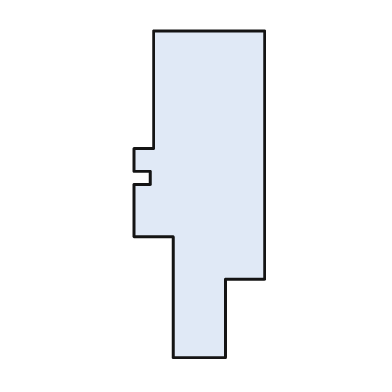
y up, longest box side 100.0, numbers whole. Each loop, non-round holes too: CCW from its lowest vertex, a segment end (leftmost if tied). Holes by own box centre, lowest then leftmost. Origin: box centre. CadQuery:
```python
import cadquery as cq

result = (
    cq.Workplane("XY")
    .moveTo(-8.0, -50.0)
    .lineTo(8.0, -50.0)
    .lineTo(8.0, -26.0)
    .lineTo(20.0, -26.0)
    .lineTo(20.0, 50.0)
    .lineTo(-14.0, 50.0)
    .lineTo(-14.0, 14.0)
    .lineTo(-20.0, 14.0)
    .lineTo(-20.0, 7.0)
    .lineTo(-15.0, 7.0)
    .lineTo(-15.0, 3.0)
    .lineTo(-20.0, 3.0)
    .lineTo(-20.0, -13.0)
    .lineTo(-8.0, -13.0)
    .close()
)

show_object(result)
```